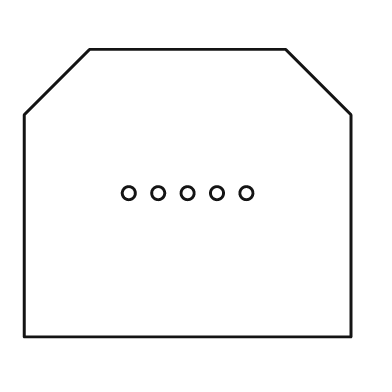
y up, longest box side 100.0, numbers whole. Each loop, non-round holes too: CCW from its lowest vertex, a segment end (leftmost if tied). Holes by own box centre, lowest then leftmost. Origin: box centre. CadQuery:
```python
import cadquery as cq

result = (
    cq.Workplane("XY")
    .moveTo(-50.0, -44.0)
    .lineTo(50.0, -44.0)
    .lineTo(50.0, 24.0)
    .lineTo(30.0, 44.0)
    .lineTo(-30.0, 44.0)
    .lineTo(-50.0, 24.0)
    .close()
    .moveTo(-18.0, 0.0)
    .circle(2.0)
    .moveTo(-9.0, 0.0)
    .circle(2.0)
    .moveTo(0.0, 0.0)
    .circle(2.0)
    .moveTo(9.0, 0.0)
    .circle(2.0)
    .moveTo(18.0, 0.0)
    .circle(2.0)
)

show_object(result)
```